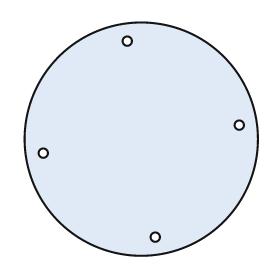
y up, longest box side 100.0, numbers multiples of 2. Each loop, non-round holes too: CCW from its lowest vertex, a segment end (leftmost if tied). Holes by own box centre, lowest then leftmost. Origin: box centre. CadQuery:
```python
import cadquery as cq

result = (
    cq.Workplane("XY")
    .moveTo(0.0, 0.0)
    .circle(50.0)
    .moveTo(6.0, -42.0)
    .circle(2.0)
    .moveTo(-42.0, -6.0)
    .circle(2.0)
    .moveTo(42.0, 6.0)
    .circle(2.0)
    .moveTo(-6.0, 42.0)
    .circle(2.0)
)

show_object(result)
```